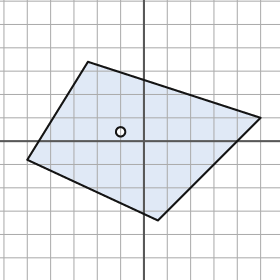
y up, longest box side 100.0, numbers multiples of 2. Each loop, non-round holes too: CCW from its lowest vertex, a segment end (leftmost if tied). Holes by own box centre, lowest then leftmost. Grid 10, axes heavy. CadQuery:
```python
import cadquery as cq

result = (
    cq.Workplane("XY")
    .moveTo(6.0, -34.0)
    .lineTo(50.0, 10.0)
    .lineTo(-24.0, 34.0)
    .lineTo(-50.0, -8.0)
    .close()
    .moveTo(-10.0, 4.0)
    .circle(2.0)
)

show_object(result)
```